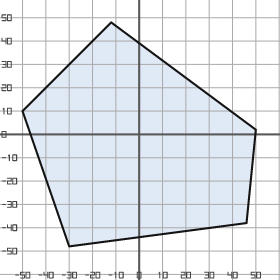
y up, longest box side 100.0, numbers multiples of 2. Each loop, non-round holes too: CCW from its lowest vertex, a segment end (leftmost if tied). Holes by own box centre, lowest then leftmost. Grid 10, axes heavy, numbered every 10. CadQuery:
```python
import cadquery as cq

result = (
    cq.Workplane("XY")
    .moveTo(-30.0, -48.0)
    .lineTo(46.0, -38.0)
    .lineTo(50.0, 2.0)
    .lineTo(-12.0, 48.0)
    .lineTo(-50.0, 10.0)
    .close()
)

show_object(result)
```